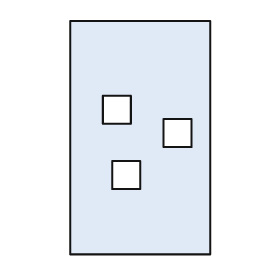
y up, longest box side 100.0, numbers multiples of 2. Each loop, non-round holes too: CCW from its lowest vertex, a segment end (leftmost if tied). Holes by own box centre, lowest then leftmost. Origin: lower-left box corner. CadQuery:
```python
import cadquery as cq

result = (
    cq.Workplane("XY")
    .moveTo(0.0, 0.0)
    .lineTo(60.0, 0.0)
    .lineTo(60.0, 100.0)
    .lineTo(0.0, 100.0)
    .close()
    .moveTo(18.0, 28.0)
    .lineTo(30.0, 28.0)
    .lineTo(30.0, 40.0)
    .lineTo(18.0, 40.0)
    .close()
    .moveTo(40.0, 46.0)
    .lineTo(52.0, 46.0)
    .lineTo(52.0, 58.0)
    .lineTo(40.0, 58.0)
    .close()
    .moveTo(14.0, 56.0)
    .lineTo(26.0, 56.0)
    .lineTo(26.0, 68.0)
    .lineTo(14.0, 68.0)
    .close()
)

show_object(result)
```